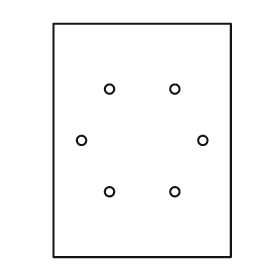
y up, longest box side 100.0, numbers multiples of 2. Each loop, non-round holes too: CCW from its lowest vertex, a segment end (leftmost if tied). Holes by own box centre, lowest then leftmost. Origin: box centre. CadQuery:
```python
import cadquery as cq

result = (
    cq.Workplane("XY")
    .moveTo(-38.0, -50.0)
    .lineTo(38.0, -50.0)
    .lineTo(38.0, 50.0)
    .lineTo(-38.0, 50.0)
    .close()
    .moveTo(-14.0, -22.0)
    .circle(2.0)
    .moveTo(14.0, -22.0)
    .circle(2.0)
    .moveTo(-26.0, 0.0)
    .circle(2.0)
    .moveTo(26.0, 0.0)
    .circle(2.0)
    .moveTo(-14.0, 22.0)
    .circle(2.0)
    .moveTo(14.0, 22.0)
    .circle(2.0)
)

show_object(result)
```